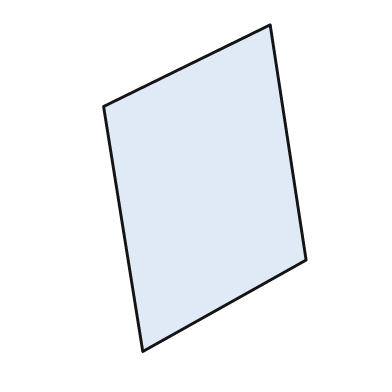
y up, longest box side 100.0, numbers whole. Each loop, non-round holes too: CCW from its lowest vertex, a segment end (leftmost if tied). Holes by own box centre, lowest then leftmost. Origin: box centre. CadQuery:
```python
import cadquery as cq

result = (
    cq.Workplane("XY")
    .moveTo(-19.0, -50.0)
    .lineTo(31.0, -22.0)
    .lineTo(20.0, 50.0)
    .lineTo(-31.0, 25.0)
    .close()
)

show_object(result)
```